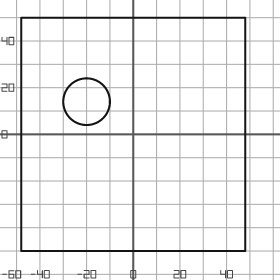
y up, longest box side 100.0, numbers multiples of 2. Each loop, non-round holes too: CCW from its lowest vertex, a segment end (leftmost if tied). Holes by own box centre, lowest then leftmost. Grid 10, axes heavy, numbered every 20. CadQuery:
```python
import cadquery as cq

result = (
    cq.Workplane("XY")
    .moveTo(-48.0, -50.0)
    .lineTo(48.0, -50.0)
    .lineTo(48.0, 50.0)
    .lineTo(-48.0, 50.0)
    .close()
    .moveTo(-20.0, 14.0)
    .circle(10.0)
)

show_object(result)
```